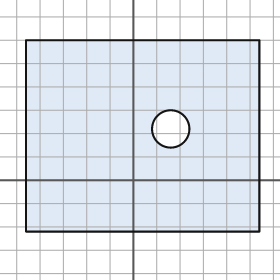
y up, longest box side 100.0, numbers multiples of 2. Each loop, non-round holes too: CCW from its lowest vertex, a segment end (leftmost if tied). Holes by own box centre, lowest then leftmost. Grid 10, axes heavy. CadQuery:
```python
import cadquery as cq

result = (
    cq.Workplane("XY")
    .moveTo(-46.0, -22.0)
    .lineTo(54.0, -22.0)
    .lineTo(54.0, 60.0)
    .lineTo(-46.0, 60.0)
    .close()
    .moveTo(16.0, 22.0)
    .circle(8.0)
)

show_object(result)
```